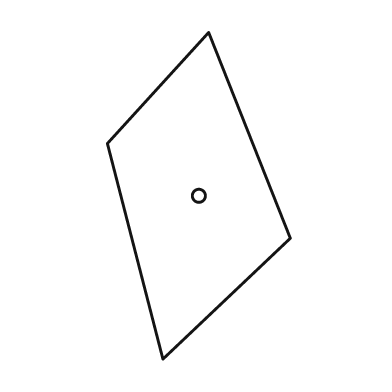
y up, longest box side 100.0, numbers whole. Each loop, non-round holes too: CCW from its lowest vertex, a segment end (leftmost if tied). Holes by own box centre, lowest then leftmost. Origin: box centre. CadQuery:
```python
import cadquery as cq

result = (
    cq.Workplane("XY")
    .moveTo(-11.0, -50.0)
    .lineTo(28.0, -13.0)
    .lineTo(3.0, 50.0)
    .lineTo(-28.0, 16.0)
    .close()
    .moveTo(0.0, 0.0)
    .circle(2.0)
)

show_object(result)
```